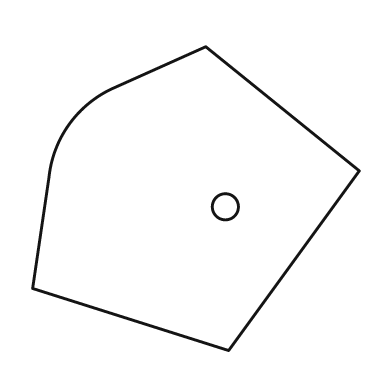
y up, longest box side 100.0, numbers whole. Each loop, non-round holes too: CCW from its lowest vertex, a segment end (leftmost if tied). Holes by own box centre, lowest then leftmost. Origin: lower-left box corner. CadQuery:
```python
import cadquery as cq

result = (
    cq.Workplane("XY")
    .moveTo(60.0, 0.0)
    .lineTo(100.0, 55.0)
    .lineTo(53.0, 93.0)
    .lineTo(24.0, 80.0)
    .threePointArc((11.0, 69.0), (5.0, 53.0))
    .lineTo(0.0, 19.0)
    .close()
    .moveTo(59.0, 44.0)
    .circle(4.0)
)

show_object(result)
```